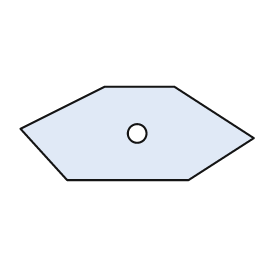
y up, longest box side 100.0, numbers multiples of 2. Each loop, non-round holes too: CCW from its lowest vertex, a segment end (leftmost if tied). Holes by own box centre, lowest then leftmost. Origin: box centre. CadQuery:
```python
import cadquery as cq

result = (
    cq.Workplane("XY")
    .moveTo(-30.0, -20.0)
    .lineTo(22.0, -20.0)
    .lineTo(50.0, -2.0)
    .lineTo(16.0, 20.0)
    .lineTo(-14.0, 20.0)
    .lineTo(-50.0, 2.0)
    .close()
    .moveTo(0.0, 0.0)
    .circle(4.0)
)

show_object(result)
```